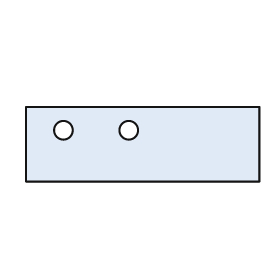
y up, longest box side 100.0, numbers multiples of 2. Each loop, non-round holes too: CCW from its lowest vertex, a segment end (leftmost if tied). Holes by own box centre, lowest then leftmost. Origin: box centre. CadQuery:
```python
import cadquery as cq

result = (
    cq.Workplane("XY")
    .moveTo(-50.0, -16.0)
    .lineTo(50.0, -16.0)
    .lineTo(50.0, 16.0)
    .lineTo(-50.0, 16.0)
    .close()
    .moveTo(-34.0, 6.0)
    .circle(4.0)
    .moveTo(-6.0, 6.0)
    .circle(4.0)
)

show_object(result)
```